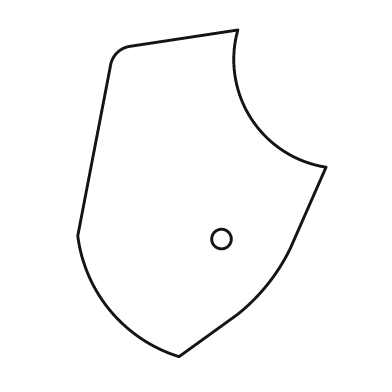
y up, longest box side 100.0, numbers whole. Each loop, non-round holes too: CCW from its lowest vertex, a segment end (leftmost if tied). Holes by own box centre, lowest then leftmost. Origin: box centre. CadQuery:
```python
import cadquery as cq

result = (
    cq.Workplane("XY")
    .moveTo(-7.0, -50.0)
    .lineTo(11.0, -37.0)
    .threePointArc((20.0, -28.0), (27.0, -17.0))
    .lineTo(38.0, 8.0)
    .threePointArc((15.0, 23.0), (11.0, 50.0))
    .lineTo(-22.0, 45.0)
    .threePointArc((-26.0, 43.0), (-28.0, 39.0))
    .lineTo(-38.0, -13.0)
    .threePointArc((-28.0, -36.0), (-7.0, -50.0))
    .close()
    .moveTo(6.0, -14.0)
    .circle(3.0)
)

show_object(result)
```